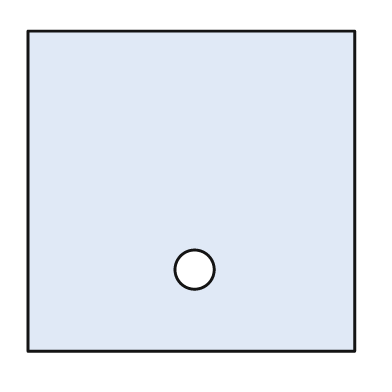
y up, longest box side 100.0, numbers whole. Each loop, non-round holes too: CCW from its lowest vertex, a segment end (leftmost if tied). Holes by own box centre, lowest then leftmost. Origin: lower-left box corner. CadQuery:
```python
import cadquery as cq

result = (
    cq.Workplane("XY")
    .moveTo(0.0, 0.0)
    .lineTo(100.0, 0.0)
    .lineTo(100.0, 98.0)
    .lineTo(0.0, 98.0)
    .close()
    .moveTo(51.0, 25.0)
    .circle(6.0)
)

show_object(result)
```